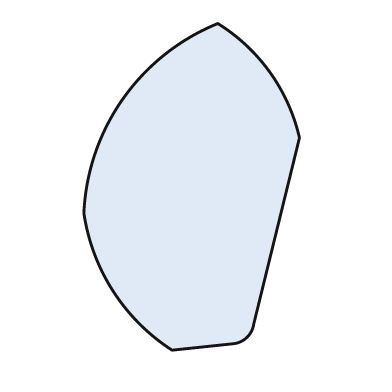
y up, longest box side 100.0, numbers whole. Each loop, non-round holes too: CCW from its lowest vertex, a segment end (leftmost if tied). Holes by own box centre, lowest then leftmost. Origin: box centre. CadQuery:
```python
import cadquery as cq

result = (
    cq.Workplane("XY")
    .moveTo(-6.0, -50.0)
    .lineTo(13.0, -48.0)
    .threePointArc((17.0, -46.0), (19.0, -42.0))
    .lineTo(33.0, 15.0)
    .threePointArc((24.0, 35.0), (8.0, 50.0))
    .threePointArc((-21.0, 27.0), (-33.0, -8.0))
    .threePointArc((-24.0, -32.0), (-6.0, -50.0))
    .close()
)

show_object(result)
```